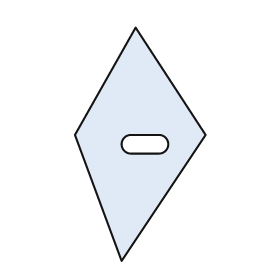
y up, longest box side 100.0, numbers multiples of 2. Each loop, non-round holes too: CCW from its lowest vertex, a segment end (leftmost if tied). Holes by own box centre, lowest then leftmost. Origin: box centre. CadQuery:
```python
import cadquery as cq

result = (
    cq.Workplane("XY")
    .moveTo(-8.0, -50.0)
    .lineTo(28.0, 4.0)
    .lineTo(-2.0, 50.0)
    .lineTo(-28.0, 4.0)
    .close()
    .moveTo(-4.0, -4.0)
    .lineTo(8.0, -4.0)
    .threePointArc((12.0, 0.0), (8.0, 4.0))
    .lineTo(-4.0, 4.0)
    .threePointArc((-8.0, 0.0), (-4.0, -4.0))
    .close()
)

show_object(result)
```